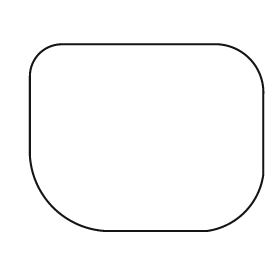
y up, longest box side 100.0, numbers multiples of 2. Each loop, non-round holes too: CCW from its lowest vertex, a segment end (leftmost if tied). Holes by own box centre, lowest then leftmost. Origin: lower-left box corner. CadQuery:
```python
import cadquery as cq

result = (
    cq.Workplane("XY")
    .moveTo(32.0, 0.0)
    .lineTo(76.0, 0.0)
    .threePointArc((92.0, 8.0), (100.0, 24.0))
    .lineTo(100.0, 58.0)
    .threePointArc((94.0, 74.0), (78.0, 80.0))
    .lineTo(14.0, 80.0)
    .threePointArc((4.0, 76.0), (0.0, 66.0))
    .lineTo(0.0, 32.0)
    .threePointArc((10.0, 10.0), (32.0, 0.0))
    .close()
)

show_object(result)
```